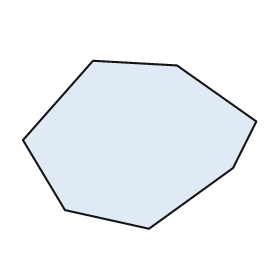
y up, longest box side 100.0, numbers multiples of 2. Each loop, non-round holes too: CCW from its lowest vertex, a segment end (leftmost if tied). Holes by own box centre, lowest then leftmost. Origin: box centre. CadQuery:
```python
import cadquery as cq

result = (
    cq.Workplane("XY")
    .moveTo(4.0, -36.0)
    .lineTo(40.0, -10.0)
    .lineTo(50.0, 10.0)
    .lineTo(16.0, 34.0)
    .lineTo(-20.0, 36.0)
    .lineTo(-50.0, 2.0)
    .lineTo(-32.0, -28.0)
    .close()
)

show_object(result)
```